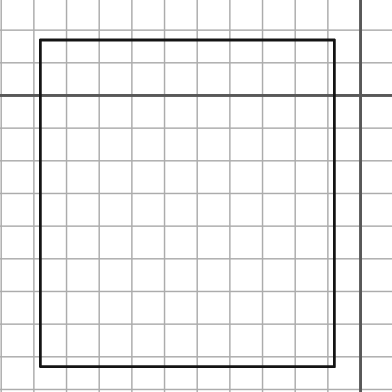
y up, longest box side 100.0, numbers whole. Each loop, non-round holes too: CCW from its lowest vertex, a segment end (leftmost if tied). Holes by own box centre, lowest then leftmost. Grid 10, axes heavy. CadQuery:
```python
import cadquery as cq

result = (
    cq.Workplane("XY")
    .moveTo(-98.0, -83.0)
    .lineTo(-8.0, -83.0)
    .lineTo(-8.0, 17.0)
    .lineTo(-98.0, 17.0)
    .close()
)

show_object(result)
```